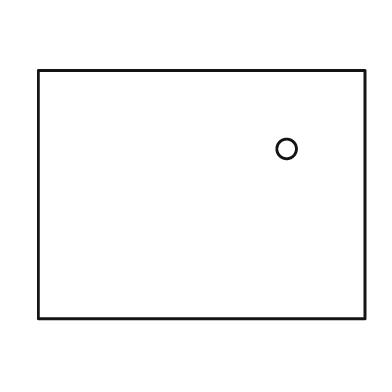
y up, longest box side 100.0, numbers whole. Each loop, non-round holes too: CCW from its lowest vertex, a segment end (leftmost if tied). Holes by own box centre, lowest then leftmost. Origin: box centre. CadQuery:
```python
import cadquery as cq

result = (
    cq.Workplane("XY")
    .moveTo(-50.0, -38.0)
    .lineTo(50.0, -38.0)
    .lineTo(50.0, 38.0)
    .lineTo(-50.0, 38.0)
    .close()
    .moveTo(26.0, 14.0)
    .circle(3.0)
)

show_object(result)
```